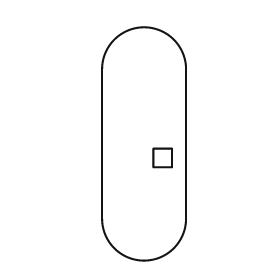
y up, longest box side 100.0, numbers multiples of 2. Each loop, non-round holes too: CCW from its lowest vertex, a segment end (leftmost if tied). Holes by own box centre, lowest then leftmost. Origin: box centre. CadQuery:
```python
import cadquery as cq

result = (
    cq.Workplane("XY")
    .moveTo(-18.0, -32.0)
    .threePointArc((0.0, -50.0), (18.0, -32.0))
    .lineTo(18.0, 32.0)
    .threePointArc((0.0, 50.0), (-18.0, 32.0))
    .close()
    .moveTo(4.0, -10.0)
    .lineTo(12.0, -10.0)
    .lineTo(12.0, -2.0)
    .lineTo(4.0, -2.0)
    .close()
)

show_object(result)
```